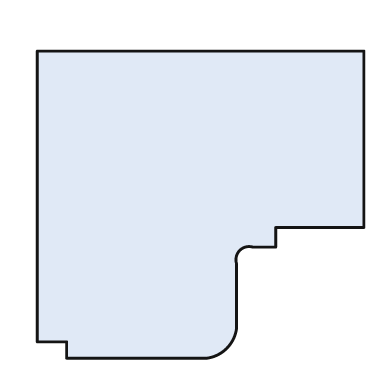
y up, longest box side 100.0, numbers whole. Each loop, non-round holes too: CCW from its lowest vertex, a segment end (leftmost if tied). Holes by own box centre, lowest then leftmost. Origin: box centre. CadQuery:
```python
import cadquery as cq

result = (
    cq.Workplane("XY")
    .moveTo(-41.0, -47.0)
    .lineTo(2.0, -47.0)
    .threePointArc((8.0, -44.0), (11.0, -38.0))
    .lineTo(11.0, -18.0)
    .threePointArc((12.0, -14.0), (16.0, -13.0))
    .lineTo(23.0, -13.0)
    .lineTo(23.0, -7.0)
    .lineTo(50.0, -7.0)
    .lineTo(50.0, 47.0)
    .lineTo(-50.0, 47.0)
    .lineTo(-50.0, -42.0)
    .lineTo(-41.0, -42.0)
    .close()
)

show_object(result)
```